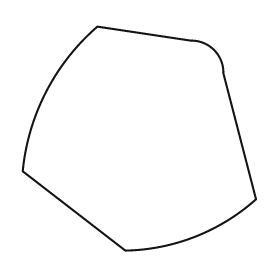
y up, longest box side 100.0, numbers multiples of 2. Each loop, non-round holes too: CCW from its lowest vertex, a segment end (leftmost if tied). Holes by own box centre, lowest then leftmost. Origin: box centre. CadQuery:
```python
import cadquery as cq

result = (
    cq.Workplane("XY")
    .moveTo(-6.0, -48.0)
    .threePointArc((24.0, -42.0), (50.0, -26.0))
    .lineTo(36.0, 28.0)
    .threePointArc((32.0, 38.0), (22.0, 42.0))
    .lineTo(-18.0, 48.0)
    .threePointArc((-40.0, 20.0), (-50.0, -14.0))
    .close()
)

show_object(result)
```